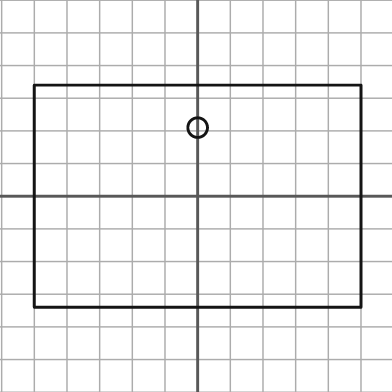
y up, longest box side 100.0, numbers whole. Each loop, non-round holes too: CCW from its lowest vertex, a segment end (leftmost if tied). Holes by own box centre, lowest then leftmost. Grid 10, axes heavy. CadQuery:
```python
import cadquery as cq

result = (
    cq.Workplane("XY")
    .moveTo(-50.0, -34.0)
    .lineTo(50.0, -34.0)
    .lineTo(50.0, 34.0)
    .lineTo(-50.0, 34.0)
    .close()
    .moveTo(0.0, 21.0)
    .circle(3.0)
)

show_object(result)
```